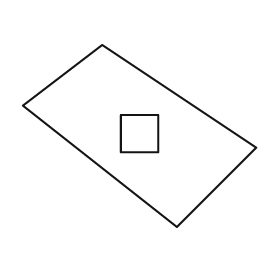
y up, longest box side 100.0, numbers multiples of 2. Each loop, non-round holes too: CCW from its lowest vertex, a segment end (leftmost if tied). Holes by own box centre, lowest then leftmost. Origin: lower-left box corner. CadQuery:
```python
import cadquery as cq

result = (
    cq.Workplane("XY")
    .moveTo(66.0, 0.0)
    .lineTo(100.0, 34.0)
    .lineTo(34.0, 78.0)
    .lineTo(0.0, 52.0)
    .close()
    .moveTo(42.0, 32.0)
    .lineTo(58.0, 32.0)
    .lineTo(58.0, 48.0)
    .lineTo(42.0, 48.0)
    .close()
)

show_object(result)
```